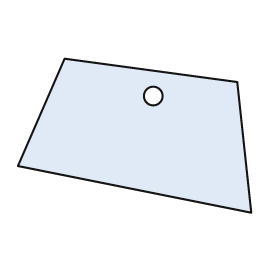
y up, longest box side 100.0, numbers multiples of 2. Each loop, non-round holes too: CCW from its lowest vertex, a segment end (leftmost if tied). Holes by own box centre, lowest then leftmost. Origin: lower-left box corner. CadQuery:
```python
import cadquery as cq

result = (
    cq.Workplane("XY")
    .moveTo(100.0, 0.0)
    .lineTo(94.0, 56.0)
    .lineTo(20.0, 66.0)
    .lineTo(0.0, 20.0)
    .close()
    .moveTo(58.0, 50.0)
    .circle(4.0)
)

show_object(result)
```